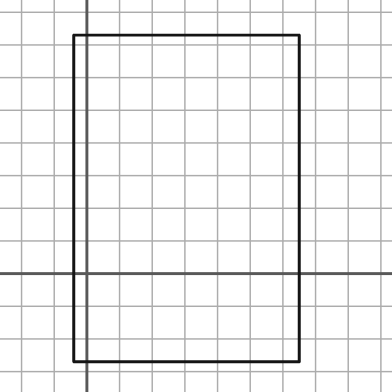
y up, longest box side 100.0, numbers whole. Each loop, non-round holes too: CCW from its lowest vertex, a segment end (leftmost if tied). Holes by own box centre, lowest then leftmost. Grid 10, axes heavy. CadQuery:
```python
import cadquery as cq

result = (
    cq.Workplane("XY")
    .moveTo(-4.0, -27.0)
    .lineTo(65.0, -27.0)
    .lineTo(65.0, 73.0)
    .lineTo(-4.0, 73.0)
    .close()
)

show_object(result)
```